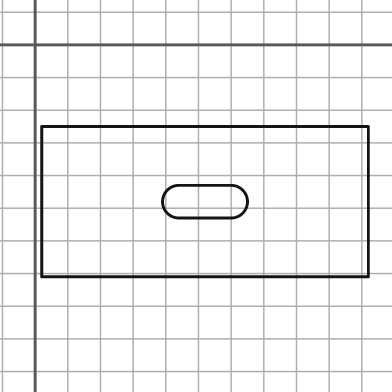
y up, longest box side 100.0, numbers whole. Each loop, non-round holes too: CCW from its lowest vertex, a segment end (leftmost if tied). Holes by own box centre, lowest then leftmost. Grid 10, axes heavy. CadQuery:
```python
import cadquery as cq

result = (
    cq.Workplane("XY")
    .moveTo(2.0, -71.0)
    .lineTo(102.0, -71.0)
    .lineTo(102.0, -25.0)
    .lineTo(2.0, -25.0)
    .close()
    .moveTo(44.0, -53.0)
    .lineTo(60.0, -53.0)
    .threePointArc((65.0, -48.0), (60.0, -43.0))
    .lineTo(44.0, -43.0)
    .threePointArc((39.0, -48.0), (44.0, -53.0))
    .close()
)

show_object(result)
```